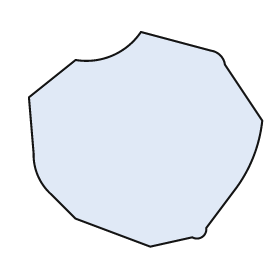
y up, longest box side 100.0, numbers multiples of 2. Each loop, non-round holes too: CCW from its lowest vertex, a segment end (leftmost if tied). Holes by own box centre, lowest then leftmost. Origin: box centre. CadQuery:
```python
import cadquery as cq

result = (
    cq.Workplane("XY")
    .moveTo(2.0, -46.0)
    .lineTo(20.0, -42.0)
    .threePointArc((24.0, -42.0), (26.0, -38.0))
    .lineTo(38.0, -22.0)
    .threePointArc((46.0, -8.0), (50.0, 8.0))
    .lineTo(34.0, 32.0)
    .threePointArc((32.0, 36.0), (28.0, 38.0))
    .lineTo(-2.0, 46.0)
    .threePointArc((-14.0, 36.0), (-30.0, 34.0))
    .lineTo(-50.0, 18.0)
    .lineTo(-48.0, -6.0)
    .threePointArc((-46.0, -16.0), (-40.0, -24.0))
    .lineTo(-30.0, -34.0)
    .close()
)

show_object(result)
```